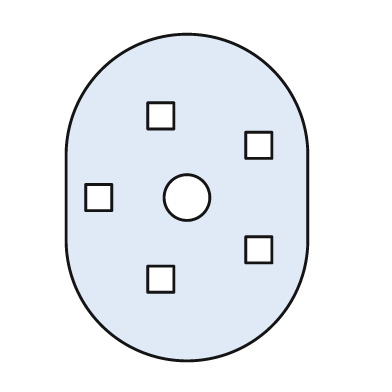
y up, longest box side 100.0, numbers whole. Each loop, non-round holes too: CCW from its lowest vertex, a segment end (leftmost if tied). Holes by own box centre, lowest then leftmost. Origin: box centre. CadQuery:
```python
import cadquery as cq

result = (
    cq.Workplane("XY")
    .moveTo(-37.0, -13.0)
    .threePointArc((0.0, -50.0), (37.0, -13.0))
    .lineTo(37.0, 13.0)
    .threePointArc((0.0, 50.0), (-37.0, 13.0))
    .close()
    .moveTo(-12.0, -29.0)
    .lineTo(-4.0, -29.0)
    .lineTo(-4.0, -21.0)
    .lineTo(-12.0, -21.0)
    .close()
    .moveTo(18.0, -20.0)
    .lineTo(26.0, -20.0)
    .lineTo(26.0, -12.0)
    .lineTo(18.0, -12.0)
    .close()
    .moveTo(-31.0, -4.0)
    .lineTo(-23.0, -4.0)
    .lineTo(-23.0, 4.0)
    .lineTo(-31.0, 4.0)
    .close()
    .moveTo(0.0, 0.0)
    .circle(7.0)
    .moveTo(18.0, 12.0)
    .lineTo(26.0, 12.0)
    .lineTo(26.0, 20.0)
    .lineTo(18.0, 20.0)
    .close()
    .moveTo(-12.0, 21.0)
    .lineTo(-4.0, 21.0)
    .lineTo(-4.0, 29.0)
    .lineTo(-12.0, 29.0)
    .close()
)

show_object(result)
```